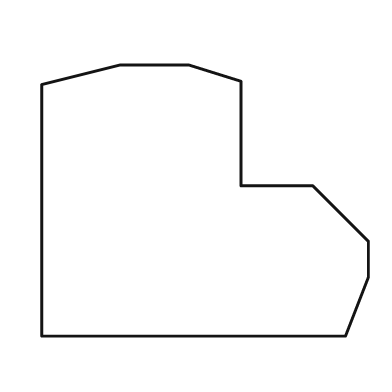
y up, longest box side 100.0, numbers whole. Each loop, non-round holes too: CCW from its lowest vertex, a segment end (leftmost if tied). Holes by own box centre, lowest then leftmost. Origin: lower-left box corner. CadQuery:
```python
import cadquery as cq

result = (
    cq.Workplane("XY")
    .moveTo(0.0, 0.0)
    .lineTo(93.0, 0.0)
    .lineTo(100.0, 18.0)
    .lineTo(100.0, 29.0)
    .lineTo(83.0, 46.0)
    .lineTo(61.0, 46.0)
    .lineTo(61.0, 78.0)
    .lineTo(45.0, 83.0)
    .lineTo(24.0, 83.0)
    .lineTo(0.0, 77.0)
    .close()
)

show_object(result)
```